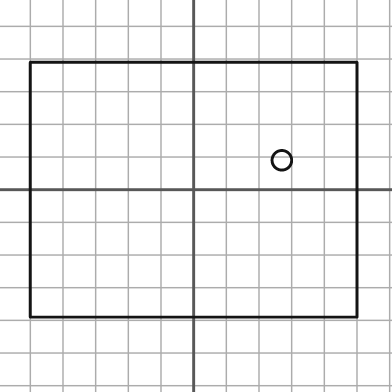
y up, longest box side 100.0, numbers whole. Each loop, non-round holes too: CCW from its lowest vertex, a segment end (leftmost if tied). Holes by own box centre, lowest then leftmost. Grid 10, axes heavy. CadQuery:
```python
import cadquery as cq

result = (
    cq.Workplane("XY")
    .moveTo(-50.0, -39.0)
    .lineTo(50.0, -39.0)
    .lineTo(50.0, 39.0)
    .lineTo(-50.0, 39.0)
    .close()
    .moveTo(27.0, 9.0)
    .circle(3.0)
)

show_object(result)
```